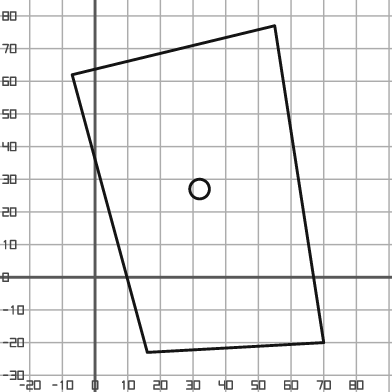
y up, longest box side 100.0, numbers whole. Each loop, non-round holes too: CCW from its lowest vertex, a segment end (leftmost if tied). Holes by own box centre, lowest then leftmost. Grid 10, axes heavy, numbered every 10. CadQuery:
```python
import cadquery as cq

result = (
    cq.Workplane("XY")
    .moveTo(16.0, -23.0)
    .lineTo(70.0, -20.0)
    .lineTo(55.0, 77.0)
    .lineTo(-7.0, 62.0)
    .close()
    .moveTo(32.0, 27.0)
    .circle(3.0)
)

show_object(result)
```